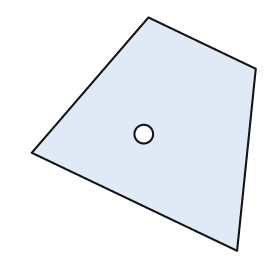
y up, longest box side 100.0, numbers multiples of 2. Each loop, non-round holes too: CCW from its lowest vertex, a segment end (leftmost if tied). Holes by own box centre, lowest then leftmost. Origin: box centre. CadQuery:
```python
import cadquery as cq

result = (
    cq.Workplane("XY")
    .moveTo(40.0, -50.0)
    .lineTo(48.0, 28.0)
    .lineTo(2.0, 50.0)
    .lineTo(-48.0, -8.0)
    .close()
    .moveTo(0.0, 0.0)
    .circle(4.0)
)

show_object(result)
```